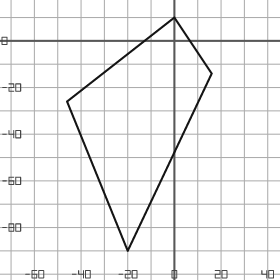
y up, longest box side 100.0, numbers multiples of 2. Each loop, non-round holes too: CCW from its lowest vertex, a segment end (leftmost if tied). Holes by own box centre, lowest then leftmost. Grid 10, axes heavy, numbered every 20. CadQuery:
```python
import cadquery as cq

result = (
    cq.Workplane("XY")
    .moveTo(-20.0, -90.0)
    .lineTo(16.0, -14.0)
    .lineTo(0.0, 10.0)
    .lineTo(-46.0, -26.0)
    .close()
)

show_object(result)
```